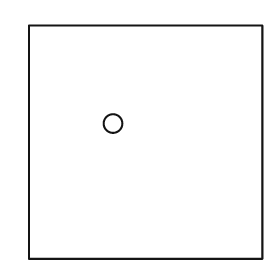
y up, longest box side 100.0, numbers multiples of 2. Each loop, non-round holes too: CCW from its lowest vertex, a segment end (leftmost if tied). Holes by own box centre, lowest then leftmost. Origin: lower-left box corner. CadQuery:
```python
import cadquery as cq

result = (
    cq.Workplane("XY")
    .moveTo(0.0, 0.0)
    .lineTo(100.0, 0.0)
    .lineTo(100.0, 100.0)
    .lineTo(0.0, 100.0)
    .close()
    .moveTo(36.0, 58.0)
    .circle(4.0)
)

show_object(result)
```